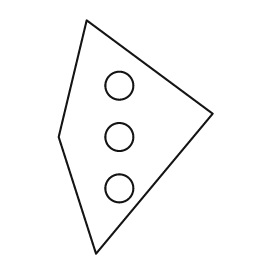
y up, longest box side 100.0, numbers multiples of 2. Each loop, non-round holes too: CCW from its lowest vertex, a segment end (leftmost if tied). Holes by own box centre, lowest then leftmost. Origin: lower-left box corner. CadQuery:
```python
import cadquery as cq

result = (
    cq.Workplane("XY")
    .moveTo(16.0, 0.0)
    .lineTo(66.0, 60.0)
    .lineTo(12.0, 100.0)
    .lineTo(0.0, 50.0)
    .close()
    .moveTo(26.0, 28.0)
    .circle(6.0)
    .moveTo(26.0, 50.0)
    .circle(6.0)
    .moveTo(26.0, 72.0)
    .circle(6.0)
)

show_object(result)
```